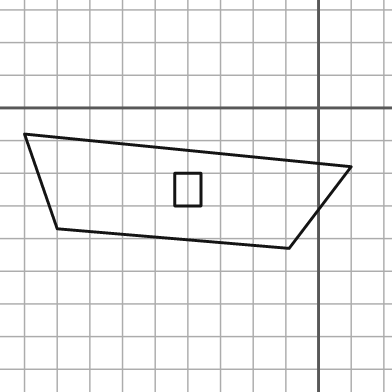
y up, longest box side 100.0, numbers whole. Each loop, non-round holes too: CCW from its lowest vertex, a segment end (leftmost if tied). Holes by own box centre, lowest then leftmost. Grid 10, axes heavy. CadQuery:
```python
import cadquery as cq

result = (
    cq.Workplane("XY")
    .moveTo(-9.0, -43.0)
    .lineTo(10.0, -18.0)
    .lineTo(-90.0, -8.0)
    .lineTo(-80.0, -37.0)
    .close()
    .moveTo(-44.0, -30.0)
    .lineTo(-36.0, -30.0)
    .lineTo(-36.0, -20.0)
    .lineTo(-44.0, -20.0)
    .close()
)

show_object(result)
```